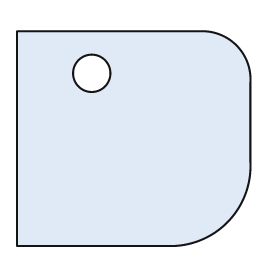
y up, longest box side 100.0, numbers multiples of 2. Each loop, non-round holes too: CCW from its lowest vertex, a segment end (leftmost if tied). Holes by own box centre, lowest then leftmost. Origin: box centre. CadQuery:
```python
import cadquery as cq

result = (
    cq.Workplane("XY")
    .moveTo(-50.0, -46.0)
    .lineTo(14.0, -46.0)
    .threePointArc((40.0, -36.0), (50.0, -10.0))
    .lineTo(50.0, 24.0)
    .threePointArc((44.0, 40.0), (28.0, 46.0))
    .lineTo(-50.0, 46.0)
    .close()
    .moveTo(-18.0, 28.0)
    .circle(8.0)
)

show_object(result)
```